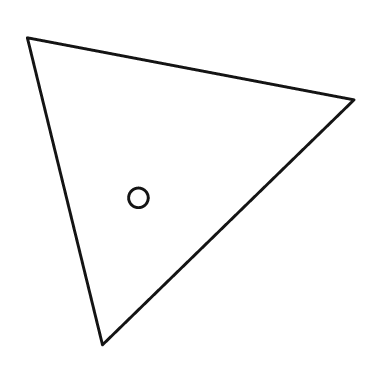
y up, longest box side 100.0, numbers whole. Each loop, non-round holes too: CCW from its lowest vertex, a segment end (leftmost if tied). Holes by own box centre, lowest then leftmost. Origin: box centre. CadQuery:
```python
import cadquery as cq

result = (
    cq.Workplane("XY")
    .moveTo(-27.0, -47.0)
    .lineTo(50.0, 28.0)
    .lineTo(-50.0, 47.0)
    .close()
    .moveTo(-16.0, -2.0)
    .circle(3.0)
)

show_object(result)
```